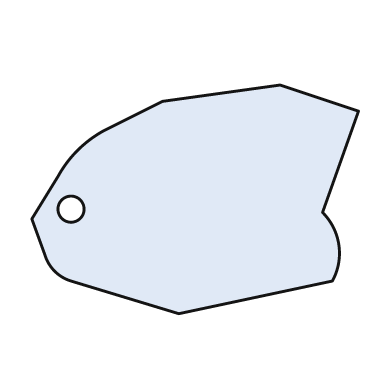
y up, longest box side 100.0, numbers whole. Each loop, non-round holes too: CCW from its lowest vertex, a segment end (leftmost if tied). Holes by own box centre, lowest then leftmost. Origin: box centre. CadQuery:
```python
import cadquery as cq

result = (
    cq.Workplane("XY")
    .moveTo(-5.0, -35.0)
    .lineTo(42.0, -25.0)
    .threePointArc((44.0, -14.0), (39.0, -4.0))
    .lineTo(50.0, 27.0)
    .lineTo(26.0, 35.0)
    .lineTo(-10.0, 30.0)
    .lineTo(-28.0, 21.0)
    .threePointArc((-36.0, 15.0), (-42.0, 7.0))
    .lineTo(-50.0, -6.0)
    .lineTo(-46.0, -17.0)
    .threePointArc((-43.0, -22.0), (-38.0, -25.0))
    .close()
    .moveTo(-38.0, -3.0)
    .circle(4.0)
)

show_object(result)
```